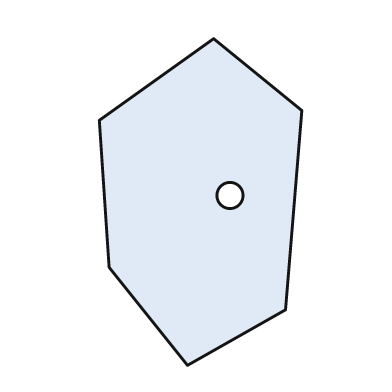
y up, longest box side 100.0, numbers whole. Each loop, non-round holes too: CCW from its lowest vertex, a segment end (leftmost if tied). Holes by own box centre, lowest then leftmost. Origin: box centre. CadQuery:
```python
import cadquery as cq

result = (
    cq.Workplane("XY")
    .moveTo(-4.0, -50.0)
    .lineTo(26.0, -33.0)
    .lineTo(31.0, 28.0)
    .lineTo(4.0, 50.0)
    .lineTo(-31.0, 25.0)
    .lineTo(-28.0, -20.0)
    .close()
    .moveTo(9.0, 2.0)
    .circle(4.0)
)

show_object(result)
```